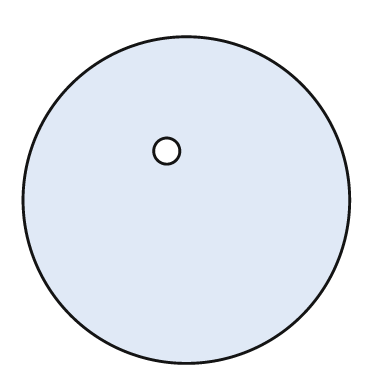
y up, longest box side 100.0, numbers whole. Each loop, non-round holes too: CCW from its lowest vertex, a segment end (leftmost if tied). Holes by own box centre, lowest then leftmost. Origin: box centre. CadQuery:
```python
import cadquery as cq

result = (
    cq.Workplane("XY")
    .moveTo(0.0, 0.0)
    .circle(50.0)
    .moveTo(-6.0, 15.0)
    .circle(4.0)
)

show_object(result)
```